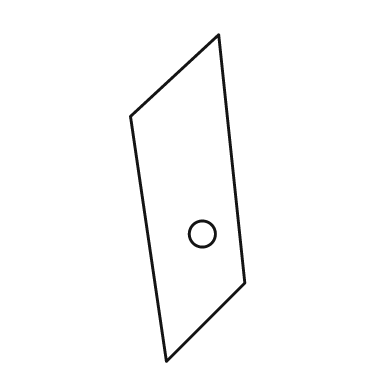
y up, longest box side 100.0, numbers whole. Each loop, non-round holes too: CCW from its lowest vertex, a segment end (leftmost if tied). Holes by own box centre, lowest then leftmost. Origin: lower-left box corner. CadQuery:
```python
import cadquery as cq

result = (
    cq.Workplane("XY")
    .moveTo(11.0, 0.0)
    .lineTo(35.0, 24.0)
    .lineTo(27.0, 100.0)
    .lineTo(0.0, 75.0)
    .close()
    .moveTo(22.0, 39.0)
    .circle(4.0)
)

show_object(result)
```